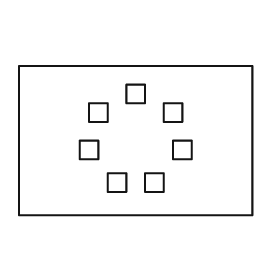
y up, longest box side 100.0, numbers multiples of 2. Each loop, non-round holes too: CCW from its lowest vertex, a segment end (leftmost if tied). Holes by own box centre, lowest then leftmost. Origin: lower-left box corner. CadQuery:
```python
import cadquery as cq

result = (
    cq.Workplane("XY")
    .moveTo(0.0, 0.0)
    .lineTo(100.0, 0.0)
    .lineTo(100.0, 64.0)
    .lineTo(0.0, 64.0)
    .close()
    .moveTo(38.0, 10.0)
    .lineTo(46.0, 10.0)
    .lineTo(46.0, 18.0)
    .lineTo(38.0, 18.0)
    .close()
    .moveTo(54.0, 10.0)
    .lineTo(62.0, 10.0)
    .lineTo(62.0, 18.0)
    .lineTo(54.0, 18.0)
    .close()
    .moveTo(26.0, 24.0)
    .lineTo(34.0, 24.0)
    .lineTo(34.0, 32.0)
    .lineTo(26.0, 32.0)
    .close()
    .moveTo(66.0, 24.0)
    .lineTo(74.0, 24.0)
    .lineTo(74.0, 32.0)
    .lineTo(66.0, 32.0)
    .close()
    .moveTo(30.0, 40.0)
    .lineTo(38.0, 40.0)
    .lineTo(38.0, 48.0)
    .lineTo(30.0, 48.0)
    .close()
    .moveTo(62.0, 40.0)
    .lineTo(70.0, 40.0)
    .lineTo(70.0, 48.0)
    .lineTo(62.0, 48.0)
    .close()
    .moveTo(46.0, 48.0)
    .lineTo(54.0, 48.0)
    .lineTo(54.0, 56.0)
    .lineTo(46.0, 56.0)
    .close()
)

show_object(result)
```